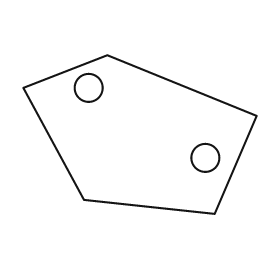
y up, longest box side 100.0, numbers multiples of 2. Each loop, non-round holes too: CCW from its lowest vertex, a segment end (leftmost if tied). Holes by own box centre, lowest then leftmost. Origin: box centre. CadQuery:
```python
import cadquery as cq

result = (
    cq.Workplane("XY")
    .moveTo(32.0, -34.0)
    .lineTo(50.0, 8.0)
    .lineTo(-14.0, 34.0)
    .lineTo(-50.0, 20.0)
    .lineTo(-24.0, -28.0)
    .close()
    .moveTo(28.0, -10.0)
    .circle(6.0)
    .moveTo(-22.0, 20.0)
    .circle(6.0)
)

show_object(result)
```